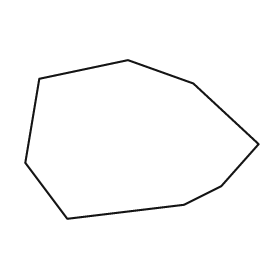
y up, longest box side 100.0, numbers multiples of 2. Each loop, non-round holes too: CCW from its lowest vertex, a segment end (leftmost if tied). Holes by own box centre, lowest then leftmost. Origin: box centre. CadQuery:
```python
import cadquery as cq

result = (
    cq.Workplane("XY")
    .moveTo(-32.0, -34.0)
    .lineTo(18.0, -28.0)
    .lineTo(34.0, -20.0)
    .lineTo(50.0, -2.0)
    .lineTo(22.0, 24.0)
    .lineTo(-6.0, 34.0)
    .lineTo(-44.0, 26.0)
    .lineTo(-50.0, -10.0)
    .close()
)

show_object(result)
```